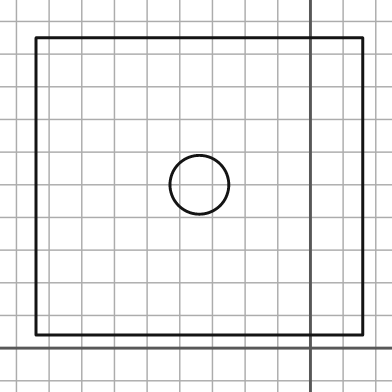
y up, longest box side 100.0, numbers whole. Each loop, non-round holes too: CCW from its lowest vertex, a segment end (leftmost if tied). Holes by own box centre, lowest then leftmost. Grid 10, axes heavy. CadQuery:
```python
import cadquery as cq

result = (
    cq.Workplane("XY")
    .moveTo(-84.0, 4.0)
    .lineTo(16.0, 4.0)
    .lineTo(16.0, 95.0)
    .lineTo(-84.0, 95.0)
    .close()
    .moveTo(-34.0, 50.0)
    .circle(9.0)
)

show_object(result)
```